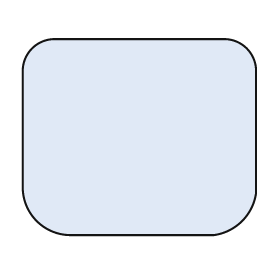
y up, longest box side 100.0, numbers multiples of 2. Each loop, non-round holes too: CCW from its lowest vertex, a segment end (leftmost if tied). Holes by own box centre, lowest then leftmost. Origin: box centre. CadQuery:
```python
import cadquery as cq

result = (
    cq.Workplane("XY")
    .moveTo(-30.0, -42.0)
    .lineTo(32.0, -42.0)
    .threePointArc((44.0, -36.0), (50.0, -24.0))
    .lineTo(50.0, 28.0)
    .threePointArc((46.0, 38.0), (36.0, 42.0))
    .lineTo(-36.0, 42.0)
    .threePointArc((-46.0, 38.0), (-50.0, 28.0))
    .lineTo(-50.0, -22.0)
    .threePointArc((-44.0, -36.0), (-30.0, -42.0))
    .close()
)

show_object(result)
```